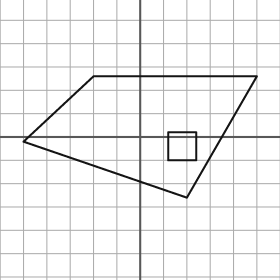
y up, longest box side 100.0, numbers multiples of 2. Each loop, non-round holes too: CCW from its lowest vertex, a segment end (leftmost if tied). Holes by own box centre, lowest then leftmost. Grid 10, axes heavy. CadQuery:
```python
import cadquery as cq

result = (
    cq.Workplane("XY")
    .moveTo(20.0, -26.0)
    .lineTo(50.0, 26.0)
    .lineTo(-20.0, 26.0)
    .lineTo(-50.0, -2.0)
    .close()
    .moveTo(12.0, -10.0)
    .lineTo(24.0, -10.0)
    .lineTo(24.0, 2.0)
    .lineTo(12.0, 2.0)
    .close()
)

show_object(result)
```